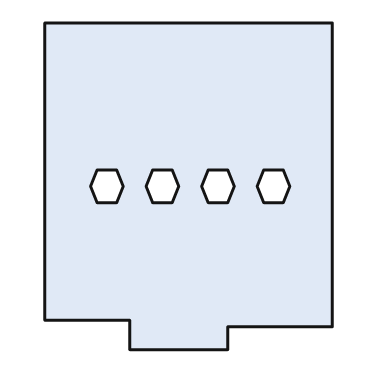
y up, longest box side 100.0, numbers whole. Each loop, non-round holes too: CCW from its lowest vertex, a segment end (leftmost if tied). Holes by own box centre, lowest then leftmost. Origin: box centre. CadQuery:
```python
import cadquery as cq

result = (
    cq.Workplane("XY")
    .moveTo(-18.0, -50.0)
    .lineTo(12.0, -50.0)
    .lineTo(12.0, -43.0)
    .lineTo(44.0, -43.0)
    .lineTo(44.0, 50.0)
    .lineTo(-44.0, 50.0)
    .lineTo(-44.0, -41.0)
    .lineTo(-18.0, -41.0)
    .close()
    .moveTo(-28.0, -5.0)
    .lineTo(-22.0, -5.0)
    .lineTo(-20.0, 0.0)
    .lineTo(-22.0, 5.0)
    .lineTo(-28.0, 5.0)
    .lineTo(-30.0, 0.0)
    .close()
    .moveTo(-11.0, -5.0)
    .lineTo(-5.0, -5.0)
    .lineTo(-3.0, 0.0)
    .lineTo(-5.0, 5.0)
    .lineTo(-11.0, 5.0)
    .lineTo(-13.0, 0.0)
    .close()
    .moveTo(6.0, -5.0)
    .lineTo(12.0, -5.0)
    .lineTo(14.0, 0.0)
    .lineTo(12.0, 5.0)
    .lineTo(6.0, 5.0)
    .lineTo(4.0, 0.0)
    .close()
    .moveTo(23.0, -5.0)
    .lineTo(29.0, -5.0)
    .lineTo(31.0, 0.0)
    .lineTo(29.0, 5.0)
    .lineTo(23.0, 5.0)
    .lineTo(21.0, 0.0)
    .close()
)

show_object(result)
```